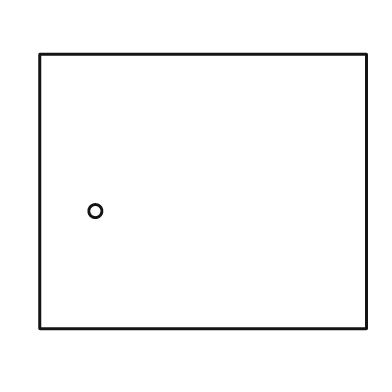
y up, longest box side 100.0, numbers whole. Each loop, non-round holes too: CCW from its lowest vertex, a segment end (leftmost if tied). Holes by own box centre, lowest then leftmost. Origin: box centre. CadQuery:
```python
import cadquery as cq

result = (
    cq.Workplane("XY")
    .moveTo(-50.0, -42.0)
    .lineTo(50.0, -42.0)
    .lineTo(50.0, 42.0)
    .lineTo(-50.0, 42.0)
    .close()
    .moveTo(-33.0, -6.0)
    .circle(2.0)
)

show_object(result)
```